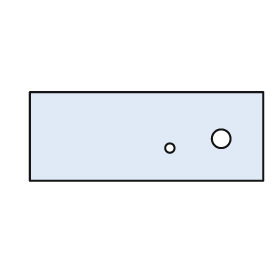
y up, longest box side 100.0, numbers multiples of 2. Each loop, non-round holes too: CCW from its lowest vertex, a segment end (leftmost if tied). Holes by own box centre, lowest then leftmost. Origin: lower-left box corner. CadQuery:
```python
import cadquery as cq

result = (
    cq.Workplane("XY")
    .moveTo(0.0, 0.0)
    .lineTo(100.0, 0.0)
    .lineTo(100.0, 38.0)
    .lineTo(0.0, 38.0)
    .close()
    .moveTo(60.0, 14.0)
    .circle(2.0)
    .moveTo(82.0, 18.0)
    .circle(4.0)
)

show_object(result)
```